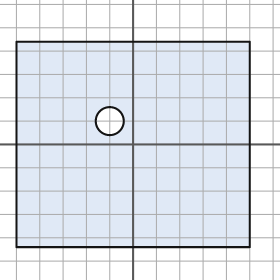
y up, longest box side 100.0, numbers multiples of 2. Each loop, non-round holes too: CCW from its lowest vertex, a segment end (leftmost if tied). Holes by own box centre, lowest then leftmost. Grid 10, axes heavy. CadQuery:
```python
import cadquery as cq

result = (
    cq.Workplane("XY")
    .moveTo(-50.0, -44.0)
    .lineTo(50.0, -44.0)
    .lineTo(50.0, 44.0)
    .lineTo(-50.0, 44.0)
    .close()
    .moveTo(-10.0, 10.0)
    .circle(6.0)
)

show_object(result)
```